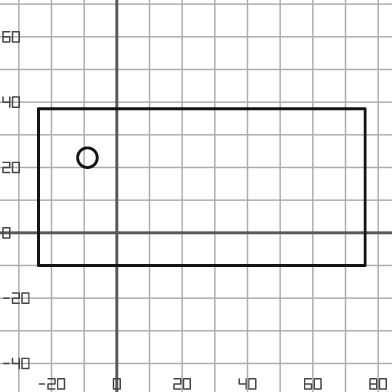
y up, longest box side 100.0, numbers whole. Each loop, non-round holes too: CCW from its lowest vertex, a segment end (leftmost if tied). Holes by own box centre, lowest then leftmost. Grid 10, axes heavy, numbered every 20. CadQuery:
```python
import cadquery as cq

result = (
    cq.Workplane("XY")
    .moveTo(-24.0, -10.0)
    .lineTo(76.0, -10.0)
    .lineTo(76.0, 38.0)
    .lineTo(-24.0, 38.0)
    .close()
    .moveTo(-9.0, 23.0)
    .circle(3.0)
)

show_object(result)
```